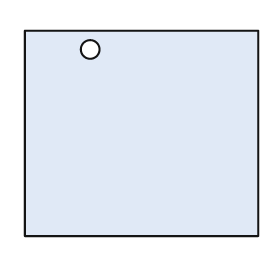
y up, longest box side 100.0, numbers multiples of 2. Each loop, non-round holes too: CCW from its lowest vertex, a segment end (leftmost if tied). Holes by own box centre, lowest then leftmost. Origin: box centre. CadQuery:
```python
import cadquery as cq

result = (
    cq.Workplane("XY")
    .moveTo(-50.0, -44.0)
    .lineTo(50.0, -44.0)
    .lineTo(50.0, 44.0)
    .lineTo(-50.0, 44.0)
    .close()
    .moveTo(-22.0, 36.0)
    .circle(4.0)
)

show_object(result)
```